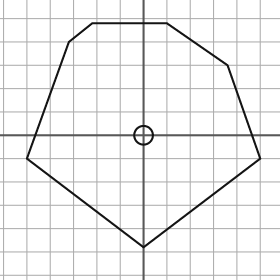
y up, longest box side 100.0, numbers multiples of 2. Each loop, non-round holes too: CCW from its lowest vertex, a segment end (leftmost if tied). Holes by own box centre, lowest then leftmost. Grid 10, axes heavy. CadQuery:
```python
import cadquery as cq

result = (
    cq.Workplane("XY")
    .moveTo(0.0, -48.0)
    .lineTo(50.0, -10.0)
    .lineTo(36.0, 30.0)
    .lineTo(10.0, 48.0)
    .lineTo(-22.0, 48.0)
    .lineTo(-32.0, 40.0)
    .lineTo(-50.0, -10.0)
    .close()
    .moveTo(0.0, 0.0)
    .circle(4.0)
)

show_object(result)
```